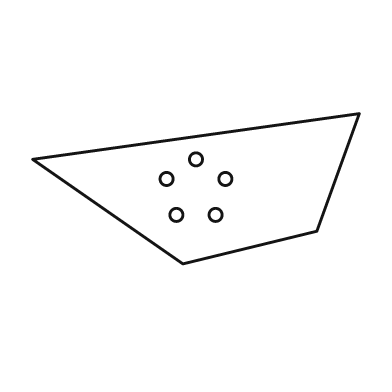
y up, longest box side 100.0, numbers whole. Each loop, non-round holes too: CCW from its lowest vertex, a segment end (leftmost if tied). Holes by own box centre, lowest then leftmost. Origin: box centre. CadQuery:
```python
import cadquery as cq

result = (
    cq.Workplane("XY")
    .moveTo(-4.0, -23.0)
    .lineTo(37.0, -13.0)
    .lineTo(50.0, 23.0)
    .lineTo(-50.0, 9.0)
    .close()
    .moveTo(-6.0, -8.0)
    .circle(2.0)
    .moveTo(6.0, -8.0)
    .circle(2.0)
    .moveTo(-9.0, 3.0)
    .circle(2.0)
    .moveTo(9.0, 3.0)
    .circle(2.0)
    .moveTo(0.0, 9.0)
    .circle(2.0)
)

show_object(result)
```